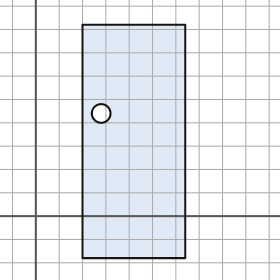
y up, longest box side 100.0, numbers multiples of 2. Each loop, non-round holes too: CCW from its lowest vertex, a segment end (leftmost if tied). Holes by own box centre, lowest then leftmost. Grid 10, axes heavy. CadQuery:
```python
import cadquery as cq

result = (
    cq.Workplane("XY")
    .moveTo(20.0, -18.0)
    .lineTo(64.0, -18.0)
    .lineTo(64.0, 82.0)
    .lineTo(20.0, 82.0)
    .close()
    .moveTo(28.0, 44.0)
    .circle(4.0)
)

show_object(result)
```